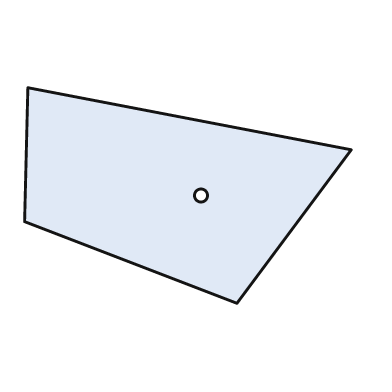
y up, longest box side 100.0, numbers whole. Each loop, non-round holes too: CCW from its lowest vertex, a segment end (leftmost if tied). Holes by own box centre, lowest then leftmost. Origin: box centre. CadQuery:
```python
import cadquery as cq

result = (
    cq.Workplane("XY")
    .moveTo(15.0, -33.0)
    .lineTo(50.0, 14.0)
    .lineTo(-49.0, 33.0)
    .lineTo(-50.0, -8.0)
    .close()
    .moveTo(4.0, 0.0)
    .circle(2.0)
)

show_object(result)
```